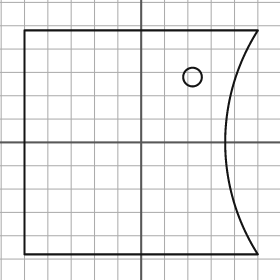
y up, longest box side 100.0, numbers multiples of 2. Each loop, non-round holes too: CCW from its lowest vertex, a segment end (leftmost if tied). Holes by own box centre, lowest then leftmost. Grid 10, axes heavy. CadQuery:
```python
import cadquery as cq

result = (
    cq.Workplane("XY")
    .moveTo(-50.0, -48.0)
    .lineTo(50.0, -48.0)
    .threePointArc((36.0, 0.0), (50.0, 48.0))
    .lineTo(-50.0, 48.0)
    .close()
    .moveTo(22.0, 28.0)
    .circle(4.0)
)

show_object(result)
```